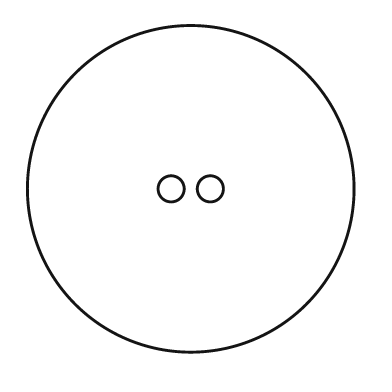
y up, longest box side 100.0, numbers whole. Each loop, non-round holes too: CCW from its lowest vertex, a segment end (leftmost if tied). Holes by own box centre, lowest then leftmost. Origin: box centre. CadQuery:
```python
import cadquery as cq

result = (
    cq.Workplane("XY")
    .moveTo(0.0, 0.0)
    .circle(50.0)
    .moveTo(-6.0, 0.0)
    .circle(4.0)
    .moveTo(6.0, 0.0)
    .circle(4.0)
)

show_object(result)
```